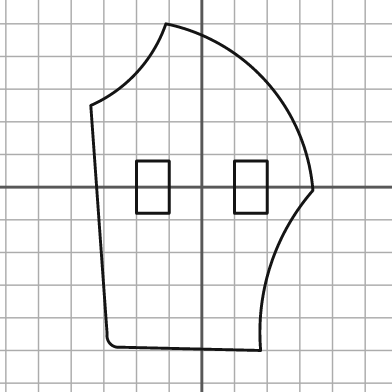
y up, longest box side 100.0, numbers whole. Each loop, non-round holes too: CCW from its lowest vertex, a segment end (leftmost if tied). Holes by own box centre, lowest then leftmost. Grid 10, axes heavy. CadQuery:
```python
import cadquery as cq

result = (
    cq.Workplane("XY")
    .moveTo(18.0, -50.0)
    .threePointArc((21.0, -24.0), (34.0, -1.0))
    .threePointArc((20.0, 32.0), (-11.0, 50.0))
    .threePointArc((-20.0, 35.0), (-34.0, 25.0))
    .lineTo(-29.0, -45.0)
    .threePointArc((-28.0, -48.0), (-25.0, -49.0))
    .close()
    .moveTo(-20.0, -8.0)
    .lineTo(-10.0, -8.0)
    .lineTo(-10.0, 8.0)
    .lineTo(-20.0, 8.0)
    .close()
    .moveTo(10.0, -8.0)
    .lineTo(20.0, -8.0)
    .lineTo(20.0, 8.0)
    .lineTo(10.0, 8.0)
    .close()
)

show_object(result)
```